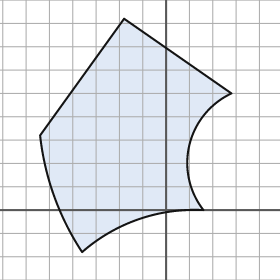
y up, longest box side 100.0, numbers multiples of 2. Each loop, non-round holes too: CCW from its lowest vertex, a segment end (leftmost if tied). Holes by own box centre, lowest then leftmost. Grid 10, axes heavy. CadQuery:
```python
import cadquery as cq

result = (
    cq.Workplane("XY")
    .moveTo(-36.0, -18.0)
    .threePointArc((-12.0, -4.0), (16.0, 0.0))
    .threePointArc((10.0, 28.0), (28.0, 50.0))
    .lineTo(-18.0, 82.0)
    .lineTo(-54.0, 32.0)
    .threePointArc((-48.0, 6.0), (-36.0, -18.0))
    .close()
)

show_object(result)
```